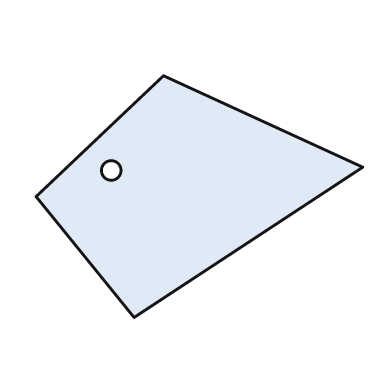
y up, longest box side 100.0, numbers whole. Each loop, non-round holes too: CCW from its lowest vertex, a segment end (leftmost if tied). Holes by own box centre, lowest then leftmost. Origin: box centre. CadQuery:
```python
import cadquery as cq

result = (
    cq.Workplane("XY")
    .moveTo(-20.0, -37.0)
    .lineTo(50.0, 9.0)
    .lineTo(-11.0, 37.0)
    .lineTo(-50.0, 0.0)
    .close()
    .moveTo(-27.0, 8.0)
    .circle(3.0)
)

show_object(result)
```